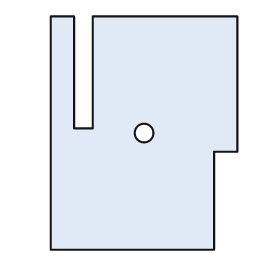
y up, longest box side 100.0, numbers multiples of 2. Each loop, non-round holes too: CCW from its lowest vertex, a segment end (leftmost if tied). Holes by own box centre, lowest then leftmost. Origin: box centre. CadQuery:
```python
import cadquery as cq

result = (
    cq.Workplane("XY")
    .moveTo(-40.0, -50.0)
    .lineTo(30.0, -50.0)
    .lineTo(30.0, -8.0)
    .lineTo(40.0, -8.0)
    .lineTo(40.0, 50.0)
    .lineTo(-22.0, 50.0)
    .lineTo(-22.0, 2.0)
    .lineTo(-30.0, 2.0)
    .lineTo(-30.0, 50.0)
    .lineTo(-40.0, 50.0)
    .close()
    .moveTo(0.0, 0.0)
    .circle(4.0)
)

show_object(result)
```